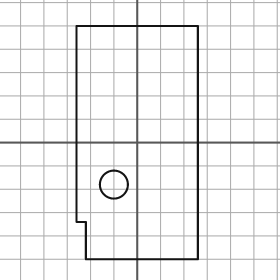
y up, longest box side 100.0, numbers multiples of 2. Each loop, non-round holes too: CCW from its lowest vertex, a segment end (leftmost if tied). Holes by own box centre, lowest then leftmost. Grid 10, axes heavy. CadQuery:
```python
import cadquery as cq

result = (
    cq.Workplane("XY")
    .moveTo(-22.0, -50.0)
    .lineTo(26.0, -50.0)
    .lineTo(26.0, 50.0)
    .lineTo(-26.0, 50.0)
    .lineTo(-26.0, -34.0)
    .lineTo(-22.0, -34.0)
    .close()
    .moveTo(-10.0, -18.0)
    .circle(6.0)
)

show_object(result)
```